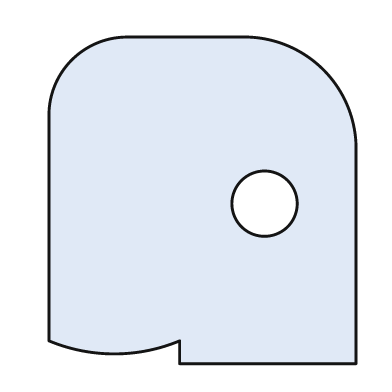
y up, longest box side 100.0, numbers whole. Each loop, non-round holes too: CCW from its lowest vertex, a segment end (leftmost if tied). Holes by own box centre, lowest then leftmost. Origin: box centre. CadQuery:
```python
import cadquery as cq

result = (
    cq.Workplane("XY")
    .moveTo(-7.0, -50.0)
    .lineTo(47.0, -50.0)
    .lineTo(47.0, 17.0)
    .threePointArc((37.0, 40.0), (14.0, 50.0))
    .lineTo(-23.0, 50.0)
    .threePointArc((-40.0, 43.0), (-47.0, 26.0))
    .lineTo(-47.0, -43.0)
    .threePointArc((-27.0, -47.0), (-7.0, -43.0))
    .close()
    .moveTo(19.0, -1.0)
    .circle(10.0)
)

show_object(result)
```